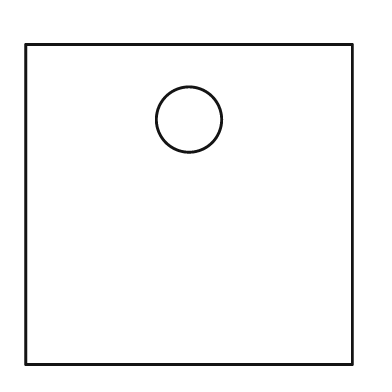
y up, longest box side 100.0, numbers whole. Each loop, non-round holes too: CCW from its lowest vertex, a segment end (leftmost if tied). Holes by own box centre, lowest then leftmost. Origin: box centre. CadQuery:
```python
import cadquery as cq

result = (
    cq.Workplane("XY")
    .moveTo(-50.0, -49.0)
    .lineTo(50.0, -49.0)
    .lineTo(50.0, 49.0)
    .lineTo(-50.0, 49.0)
    .close()
    .moveTo(0.0, 26.0)
    .circle(10.0)
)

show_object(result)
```